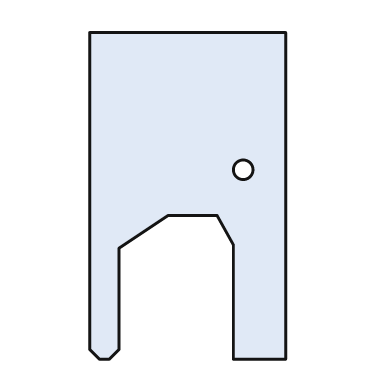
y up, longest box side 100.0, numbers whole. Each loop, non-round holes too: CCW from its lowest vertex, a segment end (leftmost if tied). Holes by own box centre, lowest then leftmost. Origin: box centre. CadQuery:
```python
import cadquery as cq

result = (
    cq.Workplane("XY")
    .moveTo(-27.0, -50.0)
    .lineTo(-24.0, -50.0)
    .lineTo(-21.0, -47.0)
    .lineTo(-21.0, -16.0)
    .lineTo(-6.0, -6.0)
    .lineTo(9.0, -6.0)
    .lineTo(14.0, -15.0)
    .lineTo(14.0, -50.0)
    .lineTo(30.0, -50.0)
    .lineTo(30.0, 50.0)
    .lineTo(-30.0, 50.0)
    .lineTo(-30.0, -47.0)
    .close()
    .moveTo(17.0, 8.0)
    .circle(3.0)
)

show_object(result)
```